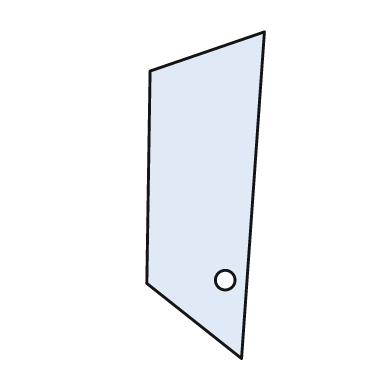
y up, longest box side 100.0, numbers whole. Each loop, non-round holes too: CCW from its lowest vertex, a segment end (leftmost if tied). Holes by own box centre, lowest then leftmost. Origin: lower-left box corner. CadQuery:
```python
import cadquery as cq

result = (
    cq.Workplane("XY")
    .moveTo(29.0, 0.0)
    .lineTo(36.0, 100.0)
    .lineTo(1.0, 88.0)
    .lineTo(0.0, 23.0)
    .close()
    .moveTo(24.0, 24.0)
    .circle(3.0)
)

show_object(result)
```